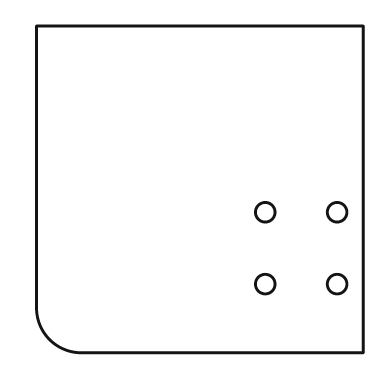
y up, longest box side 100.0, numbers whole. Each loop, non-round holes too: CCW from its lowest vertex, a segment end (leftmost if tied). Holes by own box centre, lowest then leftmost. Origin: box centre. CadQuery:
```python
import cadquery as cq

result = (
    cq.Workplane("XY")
    .moveTo(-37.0, -50.0)
    .lineTo(50.0, -50.0)
    .lineTo(50.0, 50.0)
    .lineTo(-50.0, 50.0)
    .lineTo(-50.0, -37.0)
    .threePointArc((-46.0, -46.0), (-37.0, -50.0))
    .close()
    .moveTo(20.0, -29.0)
    .circle(3.0)
    .moveTo(42.0, -29.0)
    .circle(3.0)
    .moveTo(20.0, -7.0)
    .circle(3.0)
    .moveTo(42.0, -7.0)
    .circle(3.0)
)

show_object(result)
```